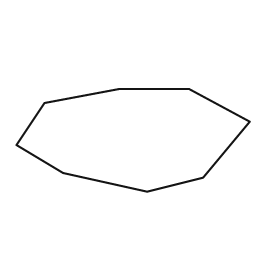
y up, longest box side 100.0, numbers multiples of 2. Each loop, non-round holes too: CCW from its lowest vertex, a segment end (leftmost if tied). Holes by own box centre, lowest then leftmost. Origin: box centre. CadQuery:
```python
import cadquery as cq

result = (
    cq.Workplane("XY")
    .moveTo(6.0, -22.0)
    .lineTo(30.0, -16.0)
    .lineTo(50.0, 8.0)
    .lineTo(24.0, 22.0)
    .lineTo(-6.0, 22.0)
    .lineTo(-38.0, 16.0)
    .lineTo(-50.0, -2.0)
    .lineTo(-30.0, -14.0)
    .close()
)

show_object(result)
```